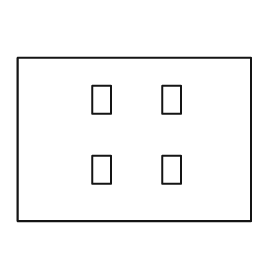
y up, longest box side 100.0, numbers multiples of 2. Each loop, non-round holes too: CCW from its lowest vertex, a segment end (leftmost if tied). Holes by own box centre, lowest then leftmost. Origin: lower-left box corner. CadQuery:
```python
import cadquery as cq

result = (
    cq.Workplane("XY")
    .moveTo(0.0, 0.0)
    .lineTo(100.0, 0.0)
    .lineTo(100.0, 70.0)
    .lineTo(0.0, 70.0)
    .close()
    .moveTo(32.0, 16.0)
    .lineTo(40.0, 16.0)
    .lineTo(40.0, 28.0)
    .lineTo(32.0, 28.0)
    .close()
    .moveTo(62.0, 16.0)
    .lineTo(70.0, 16.0)
    .lineTo(70.0, 28.0)
    .lineTo(62.0, 28.0)
    .close()
    .moveTo(32.0, 46.0)
    .lineTo(40.0, 46.0)
    .lineTo(40.0, 58.0)
    .lineTo(32.0, 58.0)
    .close()
    .moveTo(62.0, 46.0)
    .lineTo(70.0, 46.0)
    .lineTo(70.0, 58.0)
    .lineTo(62.0, 58.0)
    .close()
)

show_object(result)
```